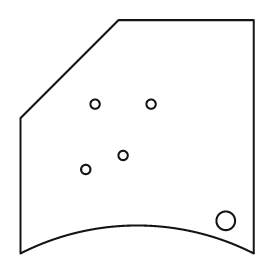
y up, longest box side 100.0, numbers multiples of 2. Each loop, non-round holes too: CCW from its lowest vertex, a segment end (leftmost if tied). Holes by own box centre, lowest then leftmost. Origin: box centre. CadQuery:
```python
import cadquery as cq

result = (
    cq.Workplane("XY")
    .moveTo(-50.0, -50.0)
    .threePointArc((0.0, -38.0), (50.0, -50.0))
    .lineTo(50.0, 50.0)
    .lineTo(-8.0, 50.0)
    .lineTo(-50.0, 8.0)
    .close()
    .moveTo(38.0, -36.0)
    .circle(4.0)
    .moveTo(-22.0, -14.0)
    .circle(2.0)
    .moveTo(-6.0, -8.0)
    .circle(2.0)
    .moveTo(-18.0, 14.0)
    .circle(2.0)
    .moveTo(6.0, 14.0)
    .circle(2.0)
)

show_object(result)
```